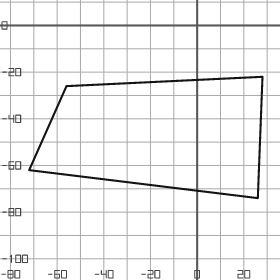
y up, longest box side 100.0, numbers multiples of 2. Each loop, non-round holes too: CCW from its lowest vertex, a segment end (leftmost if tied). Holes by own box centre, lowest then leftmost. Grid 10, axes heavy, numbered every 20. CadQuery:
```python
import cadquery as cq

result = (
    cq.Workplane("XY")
    .moveTo(26.0, -74.0)
    .lineTo(28.0, -22.0)
    .lineTo(-56.0, -26.0)
    .lineTo(-72.0, -62.0)
    .close()
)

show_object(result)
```